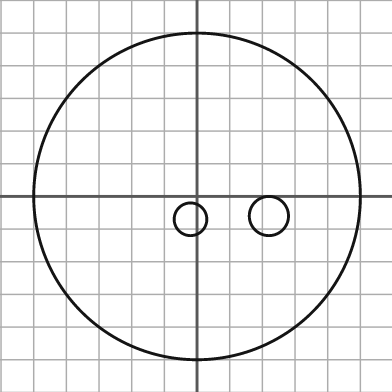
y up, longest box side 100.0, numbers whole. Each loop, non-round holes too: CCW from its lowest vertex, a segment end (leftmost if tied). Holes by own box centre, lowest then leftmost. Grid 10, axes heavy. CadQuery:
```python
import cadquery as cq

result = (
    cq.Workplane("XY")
    .moveTo(0.0, 0.0)
    .circle(50.0)
    .moveTo(-2.0, -7.0)
    .circle(5.0)
    .moveTo(22.0, -6.0)
    .circle(6.0)
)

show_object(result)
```